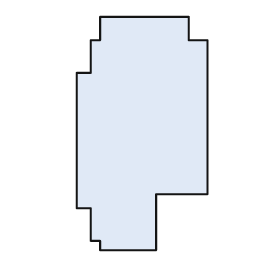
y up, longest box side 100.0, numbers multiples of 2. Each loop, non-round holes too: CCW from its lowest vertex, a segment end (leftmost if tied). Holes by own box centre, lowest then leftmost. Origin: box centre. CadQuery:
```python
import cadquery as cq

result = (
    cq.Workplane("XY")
    .moveTo(-18.0, -50.0)
    .lineTo(6.0, -50.0)
    .lineTo(6.0, -26.0)
    .lineTo(28.0, -26.0)
    .lineTo(28.0, 40.0)
    .lineTo(20.0, 40.0)
    .lineTo(20.0, 50.0)
    .lineTo(-18.0, 50.0)
    .lineTo(-18.0, 40.0)
    .lineTo(-22.0, 40.0)
    .lineTo(-22.0, 26.0)
    .lineTo(-28.0, 26.0)
    .lineTo(-28.0, -32.0)
    .lineTo(-22.0, -32.0)
    .lineTo(-22.0, -46.0)
    .lineTo(-18.0, -46.0)
    .close()
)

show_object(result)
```